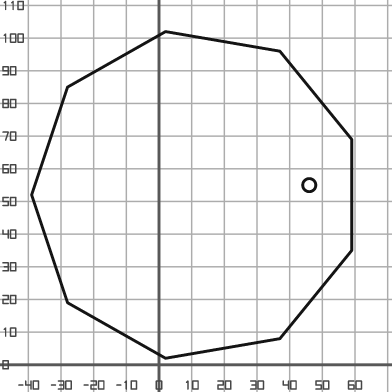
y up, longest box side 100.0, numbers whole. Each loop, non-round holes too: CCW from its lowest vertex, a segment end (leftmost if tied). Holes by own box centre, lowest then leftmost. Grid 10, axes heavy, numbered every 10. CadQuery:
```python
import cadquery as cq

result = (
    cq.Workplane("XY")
    .moveTo(2.0, 2.0)
    .lineTo(37.0, 8.0)
    .lineTo(59.0, 35.0)
    .lineTo(59.0, 69.0)
    .lineTo(37.0, 96.0)
    .lineTo(2.0, 102.0)
    .lineTo(-28.0, 85.0)
    .lineTo(-39.0, 52.0)
    .lineTo(-28.0, 19.0)
    .close()
    .moveTo(46.0, 55.0)
    .circle(2.0)
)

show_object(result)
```